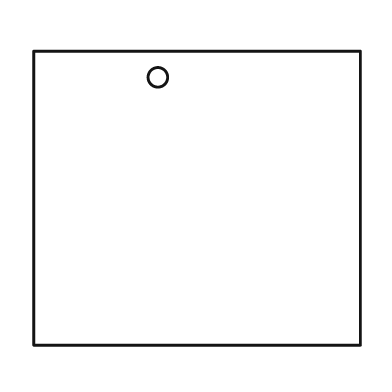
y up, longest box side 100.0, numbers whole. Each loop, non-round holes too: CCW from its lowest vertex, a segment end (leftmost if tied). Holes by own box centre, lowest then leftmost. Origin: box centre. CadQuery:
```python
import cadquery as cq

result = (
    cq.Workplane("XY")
    .moveTo(-50.0, -45.0)
    .lineTo(50.0, -45.0)
    .lineTo(50.0, 45.0)
    .lineTo(-50.0, 45.0)
    .close()
    .moveTo(-12.0, 37.0)
    .circle(3.0)
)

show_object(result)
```